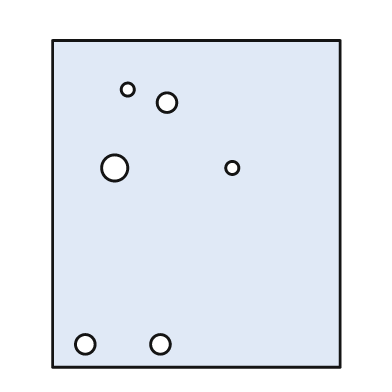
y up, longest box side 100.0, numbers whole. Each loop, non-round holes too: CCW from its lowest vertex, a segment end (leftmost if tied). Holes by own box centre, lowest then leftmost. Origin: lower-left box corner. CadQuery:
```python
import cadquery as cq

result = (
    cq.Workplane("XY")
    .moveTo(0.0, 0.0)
    .lineTo(88.0, 0.0)
    .lineTo(88.0, 100.0)
    .lineTo(0.0, 100.0)
    .close()
    .moveTo(10.0, 7.0)
    .circle(3.0)
    .moveTo(33.0, 7.0)
    .circle(3.0)
    .moveTo(19.0, 61.0)
    .circle(4.0)
    .moveTo(55.0, 61.0)
    .circle(2.0)
    .moveTo(35.0, 81.0)
    .circle(3.0)
    .moveTo(23.0, 85.0)
    .circle(2.0)
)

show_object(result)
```